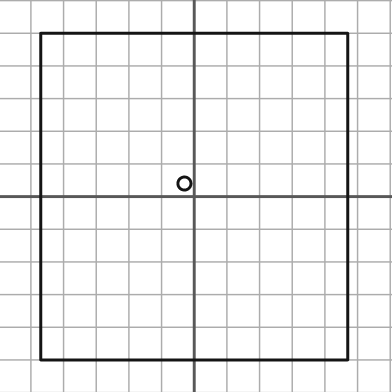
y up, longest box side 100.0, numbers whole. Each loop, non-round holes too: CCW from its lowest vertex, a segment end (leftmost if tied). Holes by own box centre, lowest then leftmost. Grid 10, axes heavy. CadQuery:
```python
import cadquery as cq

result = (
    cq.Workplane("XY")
    .moveTo(-47.0, -50.0)
    .lineTo(47.0, -50.0)
    .lineTo(47.0, 50.0)
    .lineTo(-47.0, 50.0)
    .close()
    .moveTo(-3.0, 4.0)
    .circle(2.0)
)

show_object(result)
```